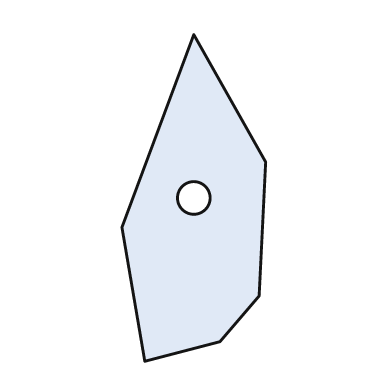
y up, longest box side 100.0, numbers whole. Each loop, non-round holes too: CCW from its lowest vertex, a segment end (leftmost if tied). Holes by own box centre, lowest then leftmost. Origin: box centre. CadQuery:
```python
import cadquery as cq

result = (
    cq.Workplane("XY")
    .moveTo(-15.0, -50.0)
    .lineTo(8.0, -44.0)
    .lineTo(20.0, -30.0)
    .lineTo(22.0, 11.0)
    .lineTo(0.0, 50.0)
    .lineTo(-22.0, -9.0)
    .close()
    .moveTo(0.0, 0.0)
    .circle(5.0)
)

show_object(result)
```